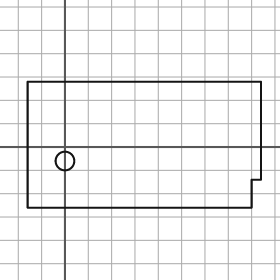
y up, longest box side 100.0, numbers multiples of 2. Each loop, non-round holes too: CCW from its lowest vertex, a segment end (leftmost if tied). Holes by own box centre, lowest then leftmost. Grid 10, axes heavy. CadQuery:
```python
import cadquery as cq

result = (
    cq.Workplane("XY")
    .moveTo(-16.0, -26.0)
    .lineTo(80.0, -26.0)
    .lineTo(80.0, -14.0)
    .lineTo(84.0, -14.0)
    .lineTo(84.0, 28.0)
    .lineTo(-16.0, 28.0)
    .close()
    .moveTo(0.0, -6.0)
    .circle(4.0)
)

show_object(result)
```